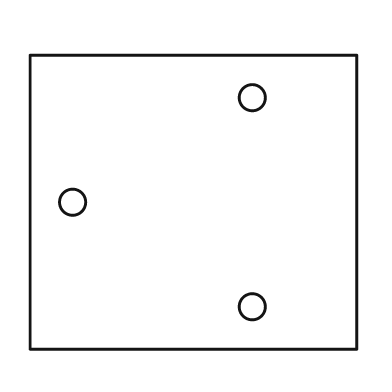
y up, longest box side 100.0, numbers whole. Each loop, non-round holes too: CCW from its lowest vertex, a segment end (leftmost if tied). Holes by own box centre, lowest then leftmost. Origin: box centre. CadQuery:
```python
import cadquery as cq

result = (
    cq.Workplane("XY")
    .moveTo(-50.0, -45.0)
    .lineTo(50.0, -45.0)
    .lineTo(50.0, 45.0)
    .lineTo(-50.0, 45.0)
    .close()
    .moveTo(18.0, -32.0)
    .circle(4.0)
    .moveTo(-37.0, 0.0)
    .circle(4.0)
    .moveTo(18.0, 32.0)
    .circle(4.0)
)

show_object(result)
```